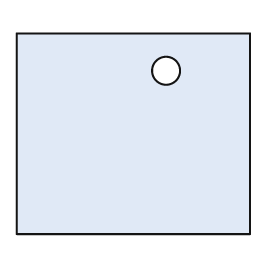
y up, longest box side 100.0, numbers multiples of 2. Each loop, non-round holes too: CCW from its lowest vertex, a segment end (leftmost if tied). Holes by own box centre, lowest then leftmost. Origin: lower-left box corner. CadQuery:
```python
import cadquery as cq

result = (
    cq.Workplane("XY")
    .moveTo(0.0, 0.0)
    .lineTo(100.0, 0.0)
    .lineTo(100.0, 86.0)
    .lineTo(0.0, 86.0)
    .close()
    .moveTo(64.0, 70.0)
    .circle(6.0)
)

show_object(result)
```